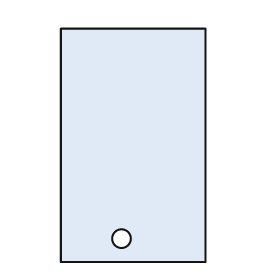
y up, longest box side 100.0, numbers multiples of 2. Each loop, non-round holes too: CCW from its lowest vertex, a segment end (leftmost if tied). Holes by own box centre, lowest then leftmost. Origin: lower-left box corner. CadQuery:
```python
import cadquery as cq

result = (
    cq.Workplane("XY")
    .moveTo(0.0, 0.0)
    .lineTo(62.0, 0.0)
    .lineTo(62.0, 100.0)
    .lineTo(0.0, 100.0)
    .close()
    .moveTo(26.0, 10.0)
    .circle(4.0)
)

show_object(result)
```